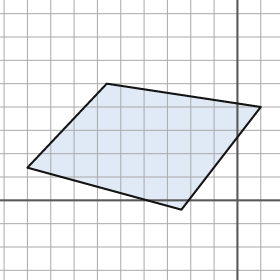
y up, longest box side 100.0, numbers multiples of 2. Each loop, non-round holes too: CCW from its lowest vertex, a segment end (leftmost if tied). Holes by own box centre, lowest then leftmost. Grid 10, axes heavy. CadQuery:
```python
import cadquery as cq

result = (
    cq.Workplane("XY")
    .moveTo(-24.0, -4.0)
    .lineTo(10.0, 40.0)
    .lineTo(-56.0, 50.0)
    .lineTo(-90.0, 14.0)
    .close()
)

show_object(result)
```